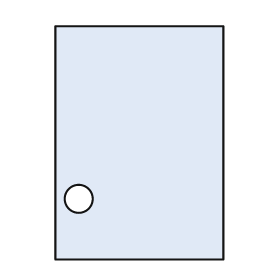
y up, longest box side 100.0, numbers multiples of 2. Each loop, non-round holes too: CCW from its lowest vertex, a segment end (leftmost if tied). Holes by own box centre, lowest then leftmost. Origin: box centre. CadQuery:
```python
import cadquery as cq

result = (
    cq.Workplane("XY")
    .moveTo(-36.0, -50.0)
    .lineTo(36.0, -50.0)
    .lineTo(36.0, 50.0)
    .lineTo(-36.0, 50.0)
    .close()
    .moveTo(-26.0, -24.0)
    .circle(6.0)
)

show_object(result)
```